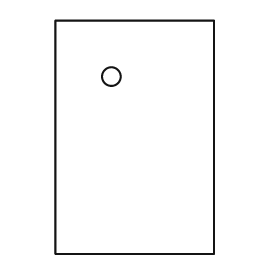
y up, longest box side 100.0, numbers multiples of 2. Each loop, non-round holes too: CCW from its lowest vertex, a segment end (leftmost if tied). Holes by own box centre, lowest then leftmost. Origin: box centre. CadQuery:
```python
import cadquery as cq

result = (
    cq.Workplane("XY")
    .moveTo(-34.0, -50.0)
    .lineTo(34.0, -50.0)
    .lineTo(34.0, 50.0)
    .lineTo(-34.0, 50.0)
    .close()
    .moveTo(-10.0, 26.0)
    .circle(4.0)
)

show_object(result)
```